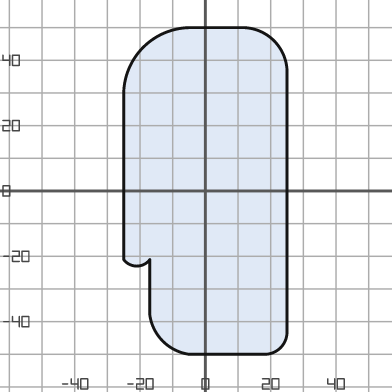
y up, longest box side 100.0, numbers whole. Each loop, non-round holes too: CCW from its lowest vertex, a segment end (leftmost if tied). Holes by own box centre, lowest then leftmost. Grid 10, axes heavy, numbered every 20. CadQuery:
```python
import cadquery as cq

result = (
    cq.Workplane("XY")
    .moveTo(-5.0, -50.0)
    .lineTo(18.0, -50.0)
    .threePointArc((23.0, -48.0), (25.0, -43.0))
    .lineTo(25.0, 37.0)
    .threePointArc((21.0, 46.0), (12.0, 50.0))
    .lineTo(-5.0, 50.0)
    .threePointArc((-19.0, 44.0), (-25.0, 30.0))
    .lineTo(-25.0, -21.0)
    .threePointArc((-21.0, -23.0), (-17.0, -21.0))
    .lineTo(-17.0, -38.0)
    .threePointArc((-13.0, -46.0), (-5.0, -50.0))
    .close()
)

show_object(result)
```